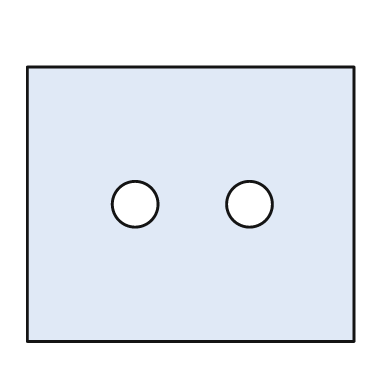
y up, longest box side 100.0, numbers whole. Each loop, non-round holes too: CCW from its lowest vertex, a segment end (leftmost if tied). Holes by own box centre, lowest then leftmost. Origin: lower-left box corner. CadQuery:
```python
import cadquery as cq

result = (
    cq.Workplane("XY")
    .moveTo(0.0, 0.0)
    .lineTo(100.0, 0.0)
    .lineTo(100.0, 84.0)
    .lineTo(0.0, 84.0)
    .close()
    .moveTo(33.0, 42.0)
    .circle(7.0)
    .moveTo(68.0, 42.0)
    .circle(7.0)
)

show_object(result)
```